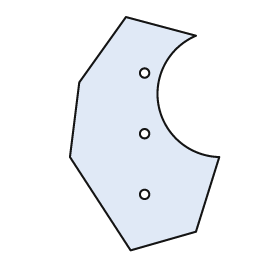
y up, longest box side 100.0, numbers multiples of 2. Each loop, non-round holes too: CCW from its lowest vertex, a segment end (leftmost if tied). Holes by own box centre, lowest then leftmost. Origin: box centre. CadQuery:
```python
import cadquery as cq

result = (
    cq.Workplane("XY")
    .moveTo(-6.0, -50.0)
    .lineTo(22.0, -42.0)
    .lineTo(32.0, -10.0)
    .threePointArc((6.0, 12.0), (22.0, 42.0))
    .lineTo(-8.0, 50.0)
    .lineTo(-28.0, 22.0)
    .lineTo(-32.0, -10.0)
    .close()
    .moveTo(0.0, -26.0)
    .circle(2.0)
    .moveTo(0.0, 0.0)
    .circle(2.0)
    .moveTo(0.0, 26.0)
    .circle(2.0)
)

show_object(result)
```